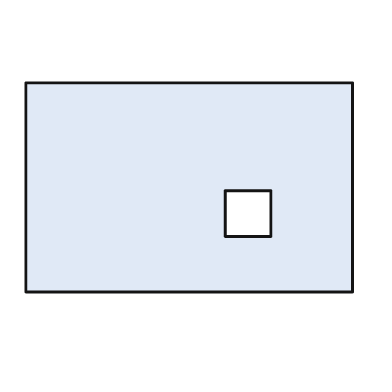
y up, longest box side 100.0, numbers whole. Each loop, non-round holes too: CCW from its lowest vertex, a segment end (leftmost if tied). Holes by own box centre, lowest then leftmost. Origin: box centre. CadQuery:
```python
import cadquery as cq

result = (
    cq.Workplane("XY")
    .moveTo(-50.0, -32.0)
    .lineTo(50.0, -32.0)
    .lineTo(50.0, 32.0)
    .lineTo(-50.0, 32.0)
    .close()
    .moveTo(11.0, -15.0)
    .lineTo(25.0, -15.0)
    .lineTo(25.0, -1.0)
    .lineTo(11.0, -1.0)
    .close()
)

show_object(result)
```